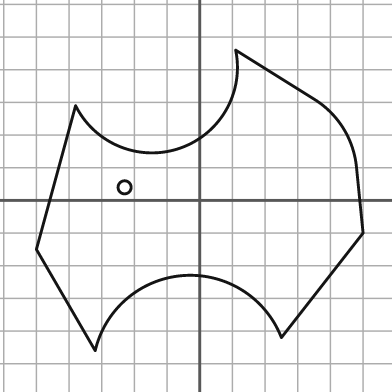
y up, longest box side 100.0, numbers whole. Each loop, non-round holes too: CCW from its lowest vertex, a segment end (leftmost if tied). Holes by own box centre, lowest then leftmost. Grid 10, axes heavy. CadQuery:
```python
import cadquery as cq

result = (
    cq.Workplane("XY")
    .moveTo(-32.0, -46.0)
    .threePointArc((-5.0, -23.0), (25.0, -42.0))
    .lineTo(50.0, -10.0)
    .lineTo(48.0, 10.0)
    .threePointArc((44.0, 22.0), (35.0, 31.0))
    .lineTo(11.0, 46.0)
    .threePointArc((-6.0, 16.0), (-38.0, 29.0))
    .lineTo(-50.0, -15.0)
    .close()
    .moveTo(-23.0, 4.0)
    .circle(2.0)
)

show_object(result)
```